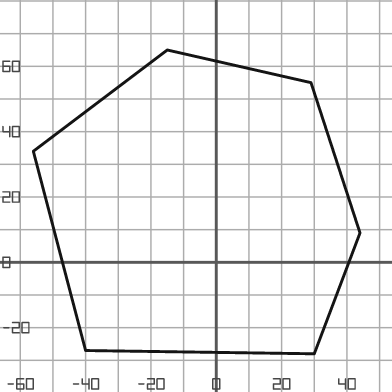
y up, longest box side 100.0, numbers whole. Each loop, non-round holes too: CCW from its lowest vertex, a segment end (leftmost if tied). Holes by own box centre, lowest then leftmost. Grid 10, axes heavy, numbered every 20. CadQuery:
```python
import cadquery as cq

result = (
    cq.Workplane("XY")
    .moveTo(30.0, -28.0)
    .lineTo(44.0, 9.0)
    .lineTo(29.0, 55.0)
    .lineTo(-15.0, 65.0)
    .lineTo(-56.0, 34.0)
    .lineTo(-40.0, -27.0)
    .close()
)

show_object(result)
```